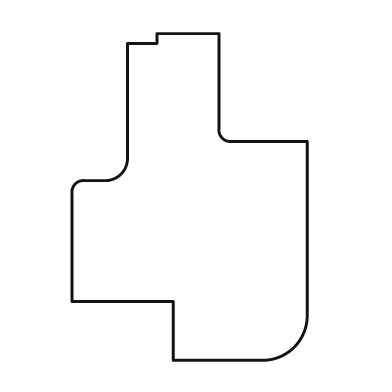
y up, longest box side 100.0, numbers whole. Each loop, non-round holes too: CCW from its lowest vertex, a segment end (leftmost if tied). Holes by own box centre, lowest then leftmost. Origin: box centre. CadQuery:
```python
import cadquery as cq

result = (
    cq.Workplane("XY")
    .moveTo(-5.0, -50.0)
    .lineTo(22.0, -50.0)
    .threePointArc((32.0, -46.0), (36.0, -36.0))
    .lineTo(36.0, 17.0)
    .lineTo(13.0, 17.0)
    .threePointArc((10.0, 18.0), (9.0, 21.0))
    .lineTo(9.0, 50.0)
    .lineTo(-10.0, 50.0)
    .lineTo(-10.0, 47.0)
    .lineTo(-19.0, 47.0)
    .lineTo(-19.0, 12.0)
    .threePointArc((-21.0, 7.0), (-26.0, 5.0))
    .lineTo(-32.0, 5.0)
    .threePointArc((-35.0, 4.0), (-36.0, 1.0))
    .lineTo(-36.0, -32.0)
    .lineTo(-5.0, -32.0)
    .close()
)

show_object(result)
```